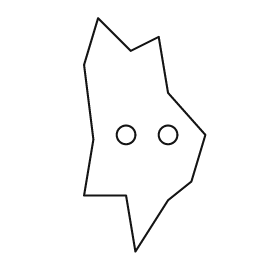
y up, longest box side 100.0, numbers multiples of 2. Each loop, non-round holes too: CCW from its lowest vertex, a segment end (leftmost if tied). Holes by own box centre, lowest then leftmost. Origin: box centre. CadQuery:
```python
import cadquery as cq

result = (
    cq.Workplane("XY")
    .moveTo(-4.0, -50.0)
    .lineTo(10.0, -28.0)
    .lineTo(20.0, -20.0)
    .lineTo(26.0, 0.0)
    .lineTo(10.0, 18.0)
    .lineTo(6.0, 42.0)
    .lineTo(-6.0, 36.0)
    .lineTo(-20.0, 50.0)
    .lineTo(-26.0, 30.0)
    .lineTo(-22.0, -2.0)
    .lineTo(-26.0, -26.0)
    .lineTo(-8.0, -26.0)
    .close()
    .moveTo(-8.0, 0.0)
    .circle(4.0)
    .moveTo(10.0, 0.0)
    .circle(4.0)
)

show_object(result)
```